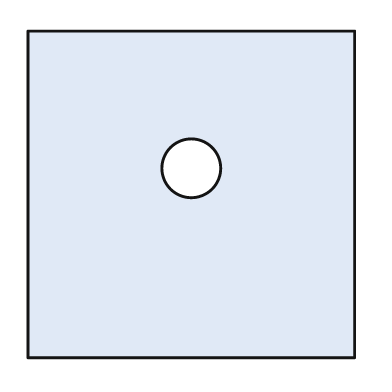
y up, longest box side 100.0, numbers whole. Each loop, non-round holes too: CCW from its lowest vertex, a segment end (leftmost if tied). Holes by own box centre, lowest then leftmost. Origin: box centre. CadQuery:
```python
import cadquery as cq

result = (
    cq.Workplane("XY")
    .moveTo(-50.0, -50.0)
    .lineTo(50.0, -50.0)
    .lineTo(50.0, 50.0)
    .lineTo(-50.0, 50.0)
    .close()
    .moveTo(0.0, 8.0)
    .circle(9.0)
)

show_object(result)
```